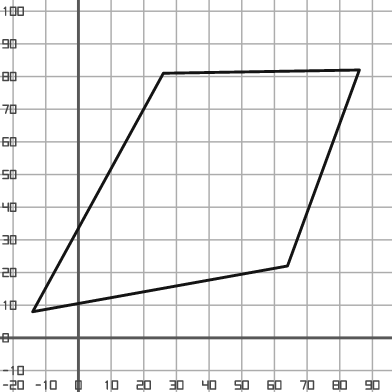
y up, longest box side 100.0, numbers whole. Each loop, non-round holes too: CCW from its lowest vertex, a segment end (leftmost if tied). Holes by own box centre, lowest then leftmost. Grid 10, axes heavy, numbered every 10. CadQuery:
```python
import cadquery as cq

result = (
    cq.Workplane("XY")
    .moveTo(-14.0, 8.0)
    .lineTo(64.0, 22.0)
    .lineTo(86.0, 82.0)
    .lineTo(26.0, 81.0)
    .close()
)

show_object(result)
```